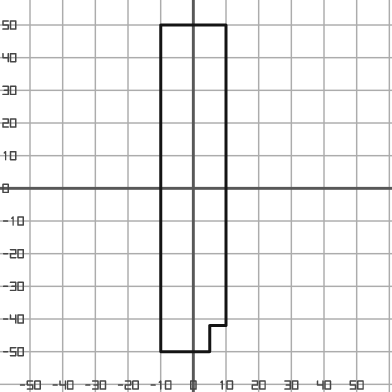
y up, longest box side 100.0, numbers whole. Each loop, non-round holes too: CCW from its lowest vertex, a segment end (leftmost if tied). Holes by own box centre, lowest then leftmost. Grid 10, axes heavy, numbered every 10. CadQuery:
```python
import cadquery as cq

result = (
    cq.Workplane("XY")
    .moveTo(-10.0, -50.0)
    .lineTo(5.0, -50.0)
    .lineTo(5.0, -42.0)
    .lineTo(10.0, -42.0)
    .lineTo(10.0, 50.0)
    .lineTo(-10.0, 50.0)
    .close()
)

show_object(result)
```